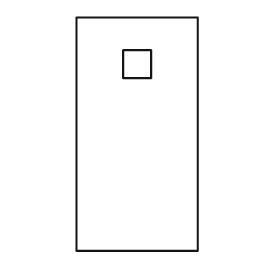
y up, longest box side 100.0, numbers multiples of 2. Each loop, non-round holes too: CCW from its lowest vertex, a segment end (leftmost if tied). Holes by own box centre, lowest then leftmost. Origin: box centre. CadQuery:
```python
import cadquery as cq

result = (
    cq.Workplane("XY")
    .moveTo(-26.0, -50.0)
    .lineTo(26.0, -50.0)
    .lineTo(26.0, 50.0)
    .lineTo(-26.0, 50.0)
    .close()
    .moveTo(-6.0, 24.0)
    .lineTo(6.0, 24.0)
    .lineTo(6.0, 36.0)
    .lineTo(-6.0, 36.0)
    .close()
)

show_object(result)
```